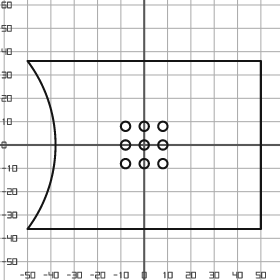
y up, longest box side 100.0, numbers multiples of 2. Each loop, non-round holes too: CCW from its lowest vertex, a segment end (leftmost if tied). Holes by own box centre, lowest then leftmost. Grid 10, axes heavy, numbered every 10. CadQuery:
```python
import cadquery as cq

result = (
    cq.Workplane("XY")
    .moveTo(-50.0, -36.0)
    .lineTo(50.0, -36.0)
    .lineTo(50.0, 36.0)
    .lineTo(-50.0, 36.0)
    .threePointArc((-38.0, 0.0), (-50.0, -36.0))
    .close()
    .moveTo(-8.0, -8.0)
    .circle(2.0)
    .moveTo(0.0, -8.0)
    .circle(2.0)
    .moveTo(8.0, -8.0)
    .circle(2.0)
    .moveTo(-8.0, 0.0)
    .circle(2.0)
    .moveTo(0.0, 0.0)
    .circle(2.0)
    .moveTo(8.0, 0.0)
    .circle(2.0)
    .moveTo(-8.0, 8.0)
    .circle(2.0)
    .moveTo(0.0, 8.0)
    .circle(2.0)
    .moveTo(8.0, 8.0)
    .circle(2.0)
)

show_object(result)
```